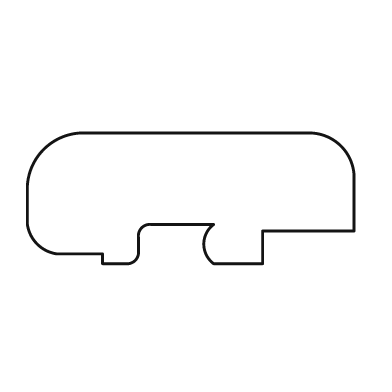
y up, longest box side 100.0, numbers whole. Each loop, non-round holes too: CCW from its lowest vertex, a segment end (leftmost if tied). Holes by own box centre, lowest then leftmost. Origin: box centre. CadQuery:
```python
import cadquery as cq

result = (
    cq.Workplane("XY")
    .moveTo(-27.0, -20.0)
    .lineTo(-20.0, -20.0)
    .threePointArc((-17.0, -19.0), (-16.0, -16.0))
    .lineTo(-16.0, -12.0)
    .threePointArc((-15.0, -9.0), (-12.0, -8.0))
    .lineTo(7.0, -8.0)
    .threePointArc((4.0, -14.0), (7.0, -20.0))
    .lineTo(22.0, -20.0)
    .lineTo(22.0, -10.0)
    .lineTo(50.0, -10.0)
    .lineTo(50.0, 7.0)
    .threePointArc((46.0, 16.0), (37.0, 20.0))
    .lineTo(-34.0, 20.0)
    .threePointArc((-45.0, 15.0), (-50.0, 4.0))
    .lineTo(-50.0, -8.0)
    .threePointArc((-47.0, -14.0), (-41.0, -17.0))
    .lineTo(-27.0, -17.0)
    .close()
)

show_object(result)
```